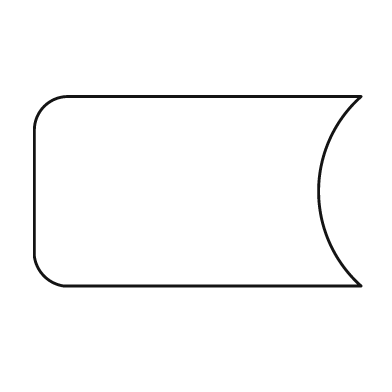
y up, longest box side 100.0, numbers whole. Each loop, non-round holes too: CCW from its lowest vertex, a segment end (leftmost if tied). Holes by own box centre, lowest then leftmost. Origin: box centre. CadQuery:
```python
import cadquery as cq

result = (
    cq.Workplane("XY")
    .moveTo(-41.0, -29.0)
    .lineTo(50.0, -29.0)
    .threePointArc((37.0, 0.0), (50.0, 29.0))
    .lineTo(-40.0, 29.0)
    .threePointArc((-47.0, 26.0), (-50.0, 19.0))
    .lineTo(-50.0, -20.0)
    .threePointArc((-47.0, -26.0), (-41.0, -29.0))
    .close()
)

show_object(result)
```